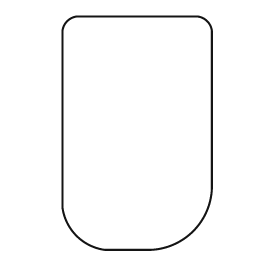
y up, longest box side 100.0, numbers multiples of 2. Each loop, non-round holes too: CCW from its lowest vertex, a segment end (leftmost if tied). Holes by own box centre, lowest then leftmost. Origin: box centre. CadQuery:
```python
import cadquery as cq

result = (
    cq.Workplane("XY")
    .moveTo(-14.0, -50.0)
    .lineTo(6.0, -50.0)
    .threePointArc((24.0, -42.0), (32.0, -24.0))
    .lineTo(32.0, 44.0)
    .threePointArc((30.0, 48.0), (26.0, 50.0))
    .lineTo(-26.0, 50.0)
    .threePointArc((-30.0, 48.0), (-32.0, 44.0))
    .lineTo(-32.0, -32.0)
    .threePointArc((-26.0, -44.0), (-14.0, -50.0))
    .close()
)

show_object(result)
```